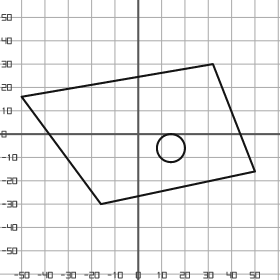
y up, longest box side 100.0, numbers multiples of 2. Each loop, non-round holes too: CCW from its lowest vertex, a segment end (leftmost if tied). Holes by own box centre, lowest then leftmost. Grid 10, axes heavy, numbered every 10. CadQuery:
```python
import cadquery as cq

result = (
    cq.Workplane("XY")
    .moveTo(-16.0, -30.0)
    .lineTo(50.0, -16.0)
    .lineTo(32.0, 30.0)
    .lineTo(-50.0, 16.0)
    .close()
    .moveTo(14.0, -6.0)
    .circle(6.0)
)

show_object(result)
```